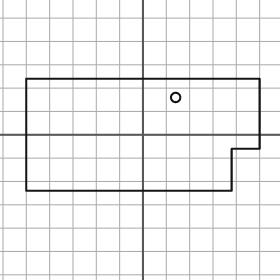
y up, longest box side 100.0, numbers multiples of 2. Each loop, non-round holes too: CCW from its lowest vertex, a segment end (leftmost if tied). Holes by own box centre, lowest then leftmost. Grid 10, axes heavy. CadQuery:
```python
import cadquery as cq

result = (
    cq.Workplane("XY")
    .moveTo(-50.0, -24.0)
    .lineTo(38.0, -24.0)
    .lineTo(38.0, -6.0)
    .lineTo(50.0, -6.0)
    .lineTo(50.0, 24.0)
    .lineTo(-50.0, 24.0)
    .close()
    .moveTo(14.0, 16.0)
    .circle(2.0)
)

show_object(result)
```